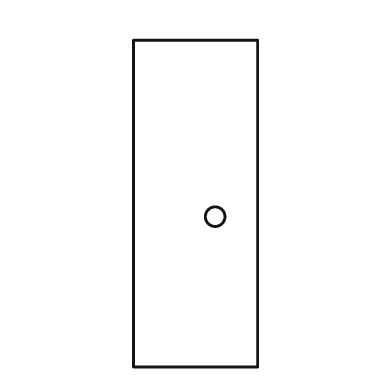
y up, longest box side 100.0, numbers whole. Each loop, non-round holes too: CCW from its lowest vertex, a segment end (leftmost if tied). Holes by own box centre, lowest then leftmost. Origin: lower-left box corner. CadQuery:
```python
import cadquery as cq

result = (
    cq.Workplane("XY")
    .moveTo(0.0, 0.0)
    .lineTo(38.0, 0.0)
    .lineTo(38.0, 100.0)
    .lineTo(0.0, 100.0)
    .close()
    .moveTo(25.0, 46.0)
    .circle(3.0)
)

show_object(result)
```